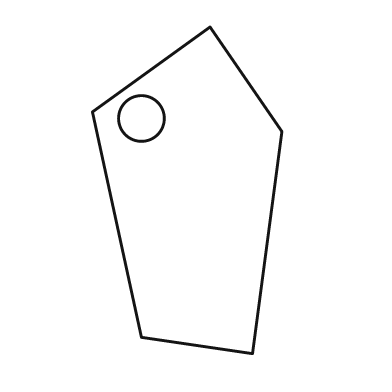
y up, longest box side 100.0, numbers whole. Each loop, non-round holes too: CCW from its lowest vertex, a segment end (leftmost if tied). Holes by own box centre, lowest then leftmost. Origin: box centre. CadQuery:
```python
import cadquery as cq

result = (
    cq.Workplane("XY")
    .moveTo(20.0, -50.0)
    .lineTo(29.0, 18.0)
    .lineTo(7.0, 50.0)
    .lineTo(-29.0, 24.0)
    .lineTo(-14.0, -45.0)
    .close()
    .moveTo(-14.0, 22.0)
    .circle(7.0)
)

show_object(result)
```